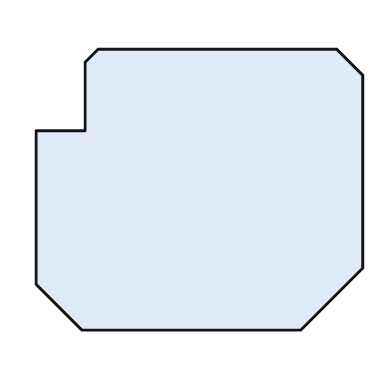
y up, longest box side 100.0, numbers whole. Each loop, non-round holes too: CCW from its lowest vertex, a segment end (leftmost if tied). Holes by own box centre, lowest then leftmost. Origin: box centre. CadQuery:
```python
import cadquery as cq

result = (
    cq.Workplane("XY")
    .moveTo(-36.0, -43.0)
    .lineTo(31.0, -43.0)
    .lineTo(50.0, -24.0)
    .lineTo(50.0, 35.0)
    .lineTo(42.0, 43.0)
    .lineTo(-31.0, 43.0)
    .lineTo(-35.0, 39.0)
    .lineTo(-35.0, 18.0)
    .lineTo(-50.0, 18.0)
    .lineTo(-50.0, -29.0)
    .close()
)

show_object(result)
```